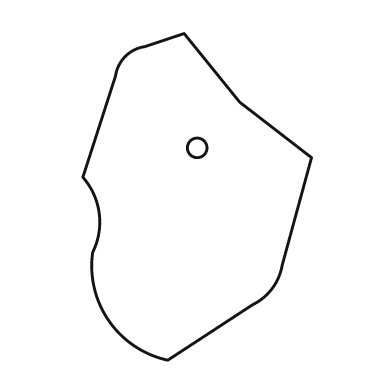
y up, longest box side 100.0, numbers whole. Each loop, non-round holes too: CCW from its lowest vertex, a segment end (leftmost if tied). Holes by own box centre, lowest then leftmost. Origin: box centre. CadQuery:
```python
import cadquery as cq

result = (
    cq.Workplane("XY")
    .moveTo(-9.0, -50.0)
    .lineTo(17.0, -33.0)
    .threePointArc((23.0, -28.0), (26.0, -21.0))
    .lineTo(35.0, 12.0)
    .lineTo(13.0, 29.0)
    .lineTo(-4.0, 50.0)
    .lineTo(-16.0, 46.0)
    .threePointArc((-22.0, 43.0), (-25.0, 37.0))
    .lineTo(-35.0, 6.0)
    .threePointArc((-30.0, -5.0), (-32.0, -17.0))
    .threePointArc((-27.0, -38.0), (-9.0, -50.0))
    .close()
    .moveTo(0.0, 15.0)
    .circle(3.0)
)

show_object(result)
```